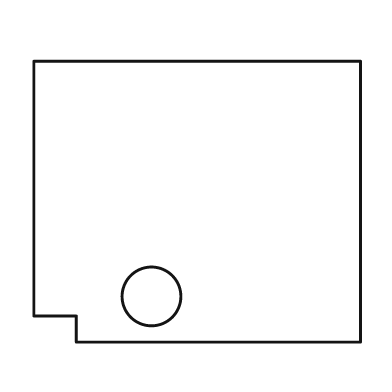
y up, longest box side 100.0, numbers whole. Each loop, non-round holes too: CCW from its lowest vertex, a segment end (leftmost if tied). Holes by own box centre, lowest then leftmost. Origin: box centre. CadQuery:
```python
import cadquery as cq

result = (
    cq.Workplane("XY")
    .moveTo(-37.0, -43.0)
    .lineTo(50.0, -43.0)
    .lineTo(50.0, 43.0)
    .lineTo(-50.0, 43.0)
    .lineTo(-50.0, -35.0)
    .lineTo(-37.0, -35.0)
    .close()
    .moveTo(-14.0, -29.0)
    .circle(9.0)
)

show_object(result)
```